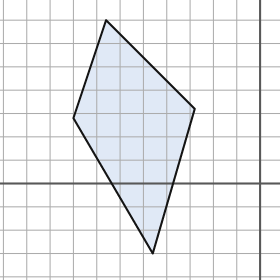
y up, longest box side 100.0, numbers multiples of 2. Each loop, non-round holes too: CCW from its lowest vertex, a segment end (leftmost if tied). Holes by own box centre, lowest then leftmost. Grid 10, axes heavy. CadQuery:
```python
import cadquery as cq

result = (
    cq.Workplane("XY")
    .moveTo(-46.0, -30.0)
    .lineTo(-28.0, 32.0)
    .lineTo(-66.0, 70.0)
    .lineTo(-80.0, 28.0)
    .close()
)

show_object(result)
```